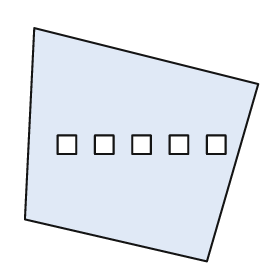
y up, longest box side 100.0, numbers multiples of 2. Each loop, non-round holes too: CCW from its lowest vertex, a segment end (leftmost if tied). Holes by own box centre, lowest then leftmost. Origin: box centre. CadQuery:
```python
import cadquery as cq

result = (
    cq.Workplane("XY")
    .moveTo(28.0, -50.0)
    .lineTo(50.0, 26.0)
    .lineTo(-46.0, 50.0)
    .lineTo(-50.0, -32.0)
    .close()
    .moveTo(-36.0, -4.0)
    .lineTo(-28.0, -4.0)
    .lineTo(-28.0, 4.0)
    .lineTo(-36.0, 4.0)
    .close()
    .moveTo(-20.0, -4.0)
    .lineTo(-12.0, -4.0)
    .lineTo(-12.0, 4.0)
    .lineTo(-20.0, 4.0)
    .close()
    .moveTo(-4.0, -4.0)
    .lineTo(4.0, -4.0)
    .lineTo(4.0, 4.0)
    .lineTo(-4.0, 4.0)
    .close()
    .moveTo(12.0, -4.0)
    .lineTo(20.0, -4.0)
    .lineTo(20.0, 4.0)
    .lineTo(12.0, 4.0)
    .close()
    .moveTo(28.0, -4.0)
    .lineTo(36.0, -4.0)
    .lineTo(36.0, 4.0)
    .lineTo(28.0, 4.0)
    .close()
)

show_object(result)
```